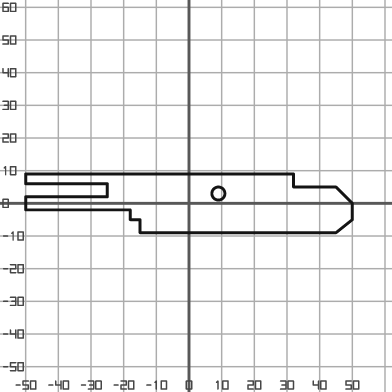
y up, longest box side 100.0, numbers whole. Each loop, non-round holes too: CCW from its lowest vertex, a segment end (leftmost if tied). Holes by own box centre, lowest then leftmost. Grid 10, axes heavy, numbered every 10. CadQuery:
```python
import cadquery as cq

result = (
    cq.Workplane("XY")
    .moveTo(-15.0, -9.0)
    .lineTo(45.0, -9.0)
    .lineTo(50.0, -5.0)
    .lineTo(50.0, 0.0)
    .lineTo(45.0, 5.0)
    .lineTo(32.0, 5.0)
    .lineTo(32.0, 9.0)
    .lineTo(-50.0, 9.0)
    .lineTo(-50.0, 6.0)
    .lineTo(-25.0, 6.0)
    .lineTo(-25.0, 2.0)
    .lineTo(-50.0, 2.0)
    .lineTo(-50.0, -2.0)
    .lineTo(-18.0, -2.0)
    .lineTo(-18.0, -5.0)
    .lineTo(-15.0, -5.0)
    .close()
    .moveTo(9.0, 3.0)
    .circle(2.0)
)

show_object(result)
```